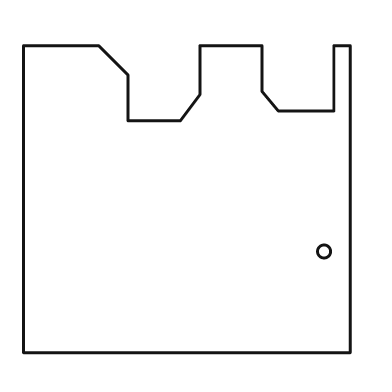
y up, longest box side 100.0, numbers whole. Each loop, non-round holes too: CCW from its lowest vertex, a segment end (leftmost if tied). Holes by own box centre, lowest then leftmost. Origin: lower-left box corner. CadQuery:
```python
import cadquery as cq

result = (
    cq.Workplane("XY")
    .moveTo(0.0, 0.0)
    .lineTo(100.0, 0.0)
    .lineTo(100.0, 94.0)
    .lineTo(95.0, 94.0)
    .lineTo(95.0, 74.0)
    .lineTo(78.0, 74.0)
    .lineTo(73.0, 80.0)
    .lineTo(73.0, 94.0)
    .lineTo(54.0, 94.0)
    .lineTo(54.0, 79.0)
    .lineTo(48.0, 71.0)
    .lineTo(32.0, 71.0)
    .lineTo(32.0, 85.0)
    .lineTo(23.0, 94.0)
    .lineTo(0.0, 94.0)
    .close()
    .moveTo(92.0, 31.0)
    .circle(2.0)
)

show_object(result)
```